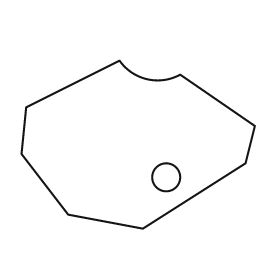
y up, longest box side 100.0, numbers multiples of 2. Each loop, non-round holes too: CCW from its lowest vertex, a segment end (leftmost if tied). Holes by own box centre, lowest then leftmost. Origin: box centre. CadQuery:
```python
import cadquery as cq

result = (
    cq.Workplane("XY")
    .moveTo(2.0, -36.0)
    .lineTo(46.0, -8.0)
    .lineTo(50.0, 8.0)
    .lineTo(18.0, 30.0)
    .threePointArc((4.0, 28.0), (-8.0, 36.0))
    .lineTo(-48.0, 16.0)
    .lineTo(-50.0, -4.0)
    .lineTo(-30.0, -30.0)
    .close()
    .moveTo(12.0, -14.0)
    .circle(6.0)
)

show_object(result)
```